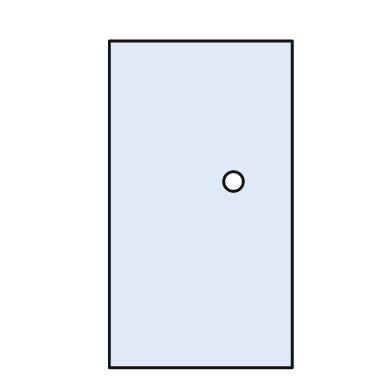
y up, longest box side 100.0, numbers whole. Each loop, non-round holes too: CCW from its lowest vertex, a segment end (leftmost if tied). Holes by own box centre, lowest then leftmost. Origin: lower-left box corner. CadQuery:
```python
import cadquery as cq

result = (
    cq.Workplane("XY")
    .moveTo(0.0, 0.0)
    .lineTo(56.0, 0.0)
    .lineTo(56.0, 100.0)
    .lineTo(0.0, 100.0)
    .close()
    .moveTo(38.0, 57.0)
    .circle(3.0)
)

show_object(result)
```